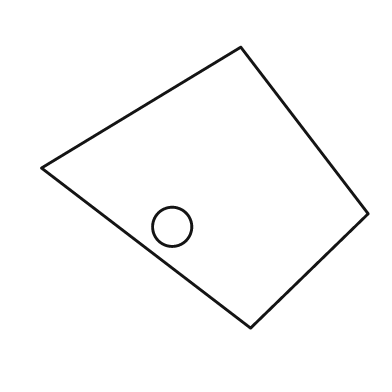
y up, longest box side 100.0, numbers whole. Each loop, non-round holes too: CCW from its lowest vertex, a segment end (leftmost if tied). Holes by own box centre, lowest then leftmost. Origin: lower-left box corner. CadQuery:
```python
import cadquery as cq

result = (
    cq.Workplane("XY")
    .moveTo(64.0, 0.0)
    .lineTo(100.0, 35.0)
    .lineTo(61.0, 86.0)
    .lineTo(0.0, 49.0)
    .close()
    .moveTo(40.0, 31.0)
    .circle(6.0)
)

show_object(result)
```